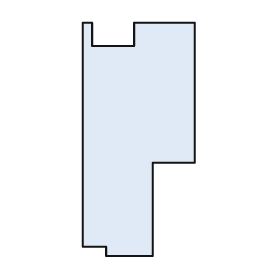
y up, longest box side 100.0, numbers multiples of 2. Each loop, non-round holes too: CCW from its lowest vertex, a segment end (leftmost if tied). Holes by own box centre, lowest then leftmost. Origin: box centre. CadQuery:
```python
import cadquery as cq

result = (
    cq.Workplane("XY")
    .moveTo(-14.0, -50.0)
    .lineTo(6.0, -50.0)
    .lineTo(6.0, -10.0)
    .lineTo(24.0, -10.0)
    .lineTo(24.0, 50.0)
    .lineTo(-2.0, 50.0)
    .lineTo(-2.0, 40.0)
    .lineTo(-20.0, 40.0)
    .lineTo(-20.0, 50.0)
    .lineTo(-24.0, 50.0)
    .lineTo(-24.0, -46.0)
    .lineTo(-14.0, -46.0)
    .close()
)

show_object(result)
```